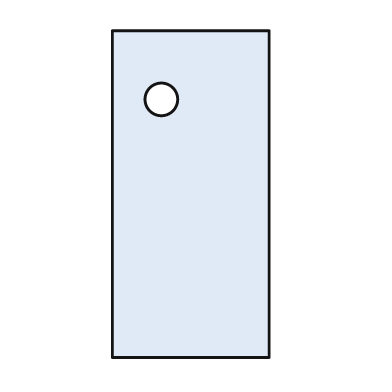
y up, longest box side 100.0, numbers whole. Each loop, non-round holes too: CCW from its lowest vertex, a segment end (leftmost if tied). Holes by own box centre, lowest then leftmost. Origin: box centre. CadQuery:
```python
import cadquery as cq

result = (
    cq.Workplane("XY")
    .moveTo(-24.0, -50.0)
    .lineTo(24.0, -50.0)
    .lineTo(24.0, 50.0)
    .lineTo(-24.0, 50.0)
    .close()
    .moveTo(-9.0, 29.0)
    .circle(5.0)
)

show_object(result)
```